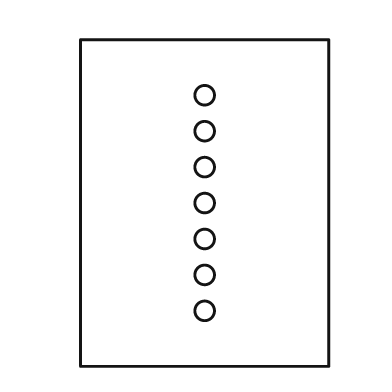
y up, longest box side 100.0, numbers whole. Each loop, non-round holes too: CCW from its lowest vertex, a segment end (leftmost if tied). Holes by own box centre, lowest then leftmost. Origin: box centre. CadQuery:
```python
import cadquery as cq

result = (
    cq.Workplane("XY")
    .moveTo(-38.0, -50.0)
    .lineTo(38.0, -50.0)
    .lineTo(38.0, 50.0)
    .lineTo(-38.0, 50.0)
    .close()
    .moveTo(0.0, -33.0)
    .circle(3.0)
    .moveTo(0.0, -22.0)
    .circle(3.0)
    .moveTo(0.0, -11.0)
    .circle(3.0)
    .moveTo(0.0, 0.0)
    .circle(3.0)
    .moveTo(0.0, 11.0)
    .circle(3.0)
    .moveTo(0.0, 22.0)
    .circle(3.0)
    .moveTo(0.0, 33.0)
    .circle(3.0)
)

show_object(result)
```